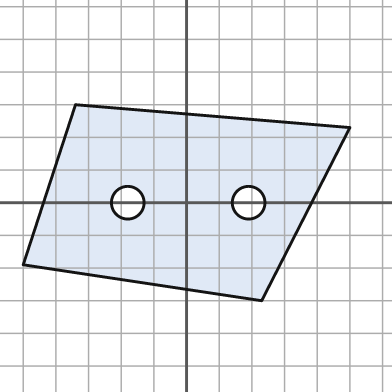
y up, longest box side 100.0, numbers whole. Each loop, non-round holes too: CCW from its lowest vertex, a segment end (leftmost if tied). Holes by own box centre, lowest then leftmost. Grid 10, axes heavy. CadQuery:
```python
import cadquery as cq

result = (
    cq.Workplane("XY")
    .moveTo(23.0, -30.0)
    .lineTo(50.0, 23.0)
    .lineTo(-34.0, 30.0)
    .lineTo(-50.0, -19.0)
    .close()
    .moveTo(-18.0, 0.0)
    .circle(5.0)
    .moveTo(19.0, 0.0)
    .circle(5.0)
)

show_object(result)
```